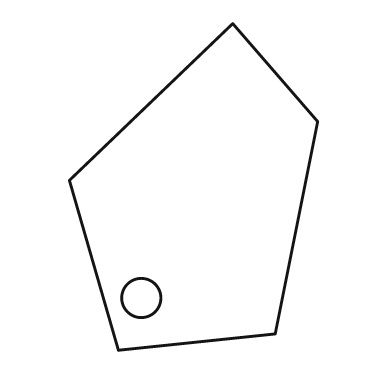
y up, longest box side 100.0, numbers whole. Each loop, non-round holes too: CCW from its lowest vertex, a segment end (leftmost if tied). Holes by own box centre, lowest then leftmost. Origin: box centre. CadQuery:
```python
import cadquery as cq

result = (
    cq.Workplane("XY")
    .moveTo(-23.0, -50.0)
    .lineTo(25.0, -45.0)
    .lineTo(38.0, 20.0)
    .lineTo(12.0, 50.0)
    .lineTo(-38.0, 2.0)
    .close()
    .moveTo(-16.0, -34.0)
    .circle(6.0)
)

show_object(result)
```